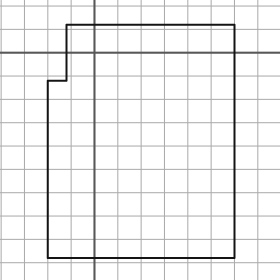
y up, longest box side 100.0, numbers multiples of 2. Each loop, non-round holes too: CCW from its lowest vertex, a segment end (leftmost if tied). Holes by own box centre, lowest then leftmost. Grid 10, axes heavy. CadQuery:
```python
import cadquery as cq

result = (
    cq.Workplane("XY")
    .moveTo(-20.0, -88.0)
    .lineTo(60.0, -88.0)
    .lineTo(60.0, 12.0)
    .lineTo(-12.0, 12.0)
    .lineTo(-12.0, -12.0)
    .lineTo(-20.0, -12.0)
    .close()
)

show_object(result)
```